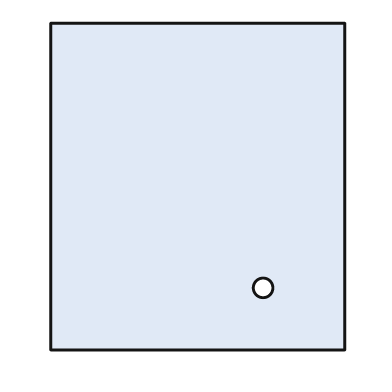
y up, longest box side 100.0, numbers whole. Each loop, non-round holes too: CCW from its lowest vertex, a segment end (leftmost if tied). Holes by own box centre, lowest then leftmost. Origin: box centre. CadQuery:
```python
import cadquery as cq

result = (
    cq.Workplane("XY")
    .moveTo(-45.0, -50.0)
    .lineTo(45.0, -50.0)
    .lineTo(45.0, 50.0)
    .lineTo(-45.0, 50.0)
    .close()
    .moveTo(20.0, -31.0)
    .circle(3.0)
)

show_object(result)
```